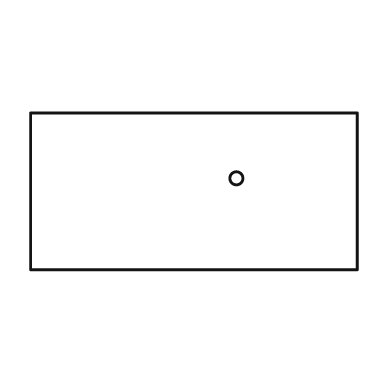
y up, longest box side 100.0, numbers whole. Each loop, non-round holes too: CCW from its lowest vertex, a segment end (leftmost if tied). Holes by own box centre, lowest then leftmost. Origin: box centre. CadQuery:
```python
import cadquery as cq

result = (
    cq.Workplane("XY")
    .moveTo(-50.0, -24.0)
    .lineTo(50.0, -24.0)
    .lineTo(50.0, 24.0)
    .lineTo(-50.0, 24.0)
    .close()
    .moveTo(13.0, 4.0)
    .circle(2.0)
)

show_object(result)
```